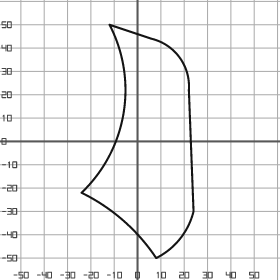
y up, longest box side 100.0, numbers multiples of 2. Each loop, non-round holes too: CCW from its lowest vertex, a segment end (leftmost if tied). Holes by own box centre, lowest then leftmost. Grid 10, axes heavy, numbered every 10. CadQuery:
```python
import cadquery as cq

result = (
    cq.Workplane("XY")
    .moveTo(8.0, -50.0)
    .threePointArc((18.0, -42.0), (24.0, -30.0))
    .lineTo(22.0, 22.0)
    .threePointArc((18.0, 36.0), (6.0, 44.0))
    .lineTo(-12.0, 50.0)
    .threePointArc((-6.0, 12.0), (-24.0, -22.0))
    .threePointArc((-6.0, -34.0), (8.0, -50.0))
    .close()
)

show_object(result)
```